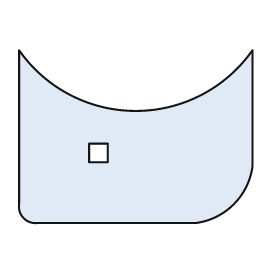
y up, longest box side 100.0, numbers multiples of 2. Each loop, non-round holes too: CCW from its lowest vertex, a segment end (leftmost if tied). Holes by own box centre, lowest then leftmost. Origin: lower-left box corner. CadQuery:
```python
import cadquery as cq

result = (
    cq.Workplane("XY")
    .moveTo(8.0, 0.0)
    .lineTo(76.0, 0.0)
    .threePointArc((92.0, 8.0), (100.0, 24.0))
    .lineTo(100.0, 74.0)
    .threePointArc((50.0, 48.0), (0.0, 74.0))
    .lineTo(0.0, 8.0)
    .threePointArc((2.0, 2.0), (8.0, 0.0))
    .close()
    .moveTo(30.0, 26.0)
    .lineTo(38.0, 26.0)
    .lineTo(38.0, 34.0)
    .lineTo(30.0, 34.0)
    .close()
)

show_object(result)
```